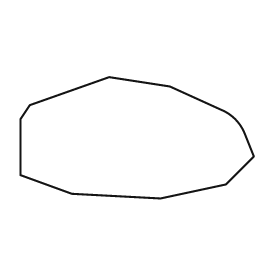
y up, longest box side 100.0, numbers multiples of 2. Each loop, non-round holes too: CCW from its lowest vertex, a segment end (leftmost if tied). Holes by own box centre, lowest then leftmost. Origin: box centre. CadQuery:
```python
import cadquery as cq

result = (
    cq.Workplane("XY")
    .moveTo(10.0, -26.0)
    .lineTo(38.0, -20.0)
    .lineTo(50.0, -8.0)
    .lineTo(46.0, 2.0)
    .threePointArc((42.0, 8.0), (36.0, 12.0))
    .lineTo(14.0, 22.0)
    .lineTo(-12.0, 26.0)
    .lineTo(-46.0, 14.0)
    .lineTo(-50.0, 8.0)
    .lineTo(-50.0, -16.0)
    .lineTo(-28.0, -24.0)
    .close()
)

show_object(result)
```